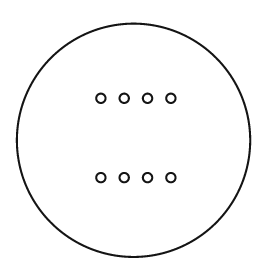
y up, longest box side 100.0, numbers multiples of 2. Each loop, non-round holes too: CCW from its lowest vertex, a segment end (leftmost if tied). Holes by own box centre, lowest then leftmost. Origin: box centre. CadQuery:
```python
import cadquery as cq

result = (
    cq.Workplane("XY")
    .moveTo(0.0, 0.0)
    .circle(50.0)
    .moveTo(-14.0, -16.0)
    .circle(2.0)
    .moveTo(-4.0, -16.0)
    .circle(2.0)
    .moveTo(6.0, -16.0)
    .circle(2.0)
    .moveTo(16.0, -16.0)
    .circle(2.0)
    .moveTo(-14.0, 18.0)
    .circle(2.0)
    .moveTo(-4.0, 18.0)
    .circle(2.0)
    .moveTo(6.0, 18.0)
    .circle(2.0)
    .moveTo(16.0, 18.0)
    .circle(2.0)
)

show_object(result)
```